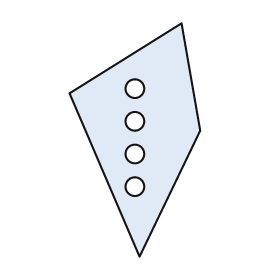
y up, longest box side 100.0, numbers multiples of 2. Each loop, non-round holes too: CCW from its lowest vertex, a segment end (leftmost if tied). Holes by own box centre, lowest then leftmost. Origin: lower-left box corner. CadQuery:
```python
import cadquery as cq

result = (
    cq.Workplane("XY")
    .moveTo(30.0, 0.0)
    .lineTo(56.0, 54.0)
    .lineTo(48.0, 100.0)
    .lineTo(0.0, 70.0)
    .close()
    .moveTo(28.0, 30.0)
    .circle(4.0)
    .moveTo(28.0, 44.0)
    .circle(4.0)
    .moveTo(28.0, 58.0)
    .circle(4.0)
    .moveTo(28.0, 72.0)
    .circle(4.0)
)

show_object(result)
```